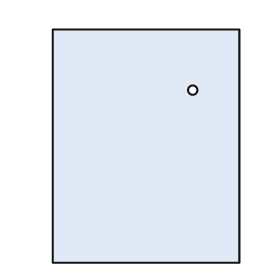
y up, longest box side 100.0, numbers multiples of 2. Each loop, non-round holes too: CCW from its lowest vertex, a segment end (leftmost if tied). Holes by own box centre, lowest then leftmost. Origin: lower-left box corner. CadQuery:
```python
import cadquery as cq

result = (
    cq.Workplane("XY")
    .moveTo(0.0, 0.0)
    .lineTo(80.0, 0.0)
    .lineTo(80.0, 100.0)
    .lineTo(0.0, 100.0)
    .close()
    .moveTo(60.0, 74.0)
    .circle(2.0)
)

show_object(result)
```